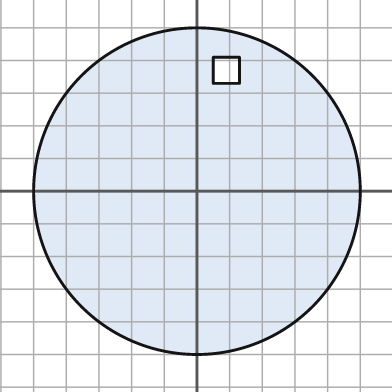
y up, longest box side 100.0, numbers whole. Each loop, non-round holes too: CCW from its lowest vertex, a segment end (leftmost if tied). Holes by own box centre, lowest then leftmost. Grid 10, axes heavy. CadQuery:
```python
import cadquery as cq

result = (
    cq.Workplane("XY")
    .moveTo(0.0, 0.0)
    .circle(50.0)
    .moveTo(5.0, 33.0)
    .lineTo(13.0, 33.0)
    .lineTo(13.0, 41.0)
    .lineTo(5.0, 41.0)
    .close()
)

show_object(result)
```